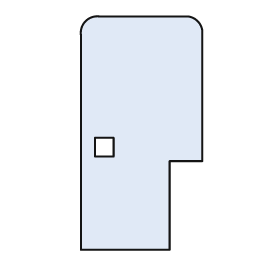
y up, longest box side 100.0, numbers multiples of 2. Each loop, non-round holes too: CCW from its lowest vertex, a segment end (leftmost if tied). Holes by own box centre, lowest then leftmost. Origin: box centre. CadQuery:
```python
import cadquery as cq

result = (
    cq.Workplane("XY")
    .moveTo(-26.0, -50.0)
    .lineTo(12.0, -50.0)
    .lineTo(12.0, -12.0)
    .lineTo(26.0, -12.0)
    .lineTo(26.0, 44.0)
    .threePointArc((24.0, 48.0), (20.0, 50.0))
    .lineTo(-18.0, 50.0)
    .threePointArc((-24.0, 48.0), (-26.0, 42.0))
    .close()
    .moveTo(-20.0, -10.0)
    .lineTo(-12.0, -10.0)
    .lineTo(-12.0, -2.0)
    .lineTo(-20.0, -2.0)
    .close()
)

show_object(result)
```